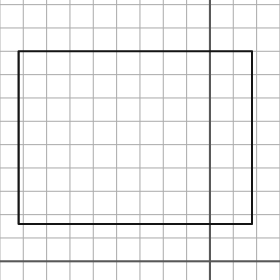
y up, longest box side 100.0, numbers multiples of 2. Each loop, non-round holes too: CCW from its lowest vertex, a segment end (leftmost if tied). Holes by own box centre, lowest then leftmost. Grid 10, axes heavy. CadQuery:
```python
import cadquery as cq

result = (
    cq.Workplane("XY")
    .moveTo(-82.0, 16.0)
    .lineTo(18.0, 16.0)
    .lineTo(18.0, 90.0)
    .lineTo(-82.0, 90.0)
    .close()
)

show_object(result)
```